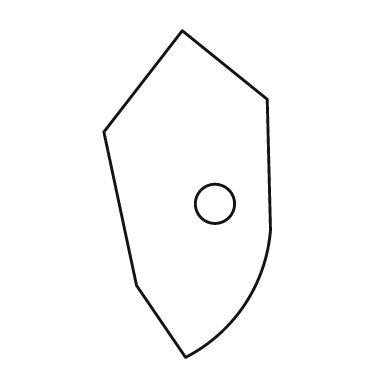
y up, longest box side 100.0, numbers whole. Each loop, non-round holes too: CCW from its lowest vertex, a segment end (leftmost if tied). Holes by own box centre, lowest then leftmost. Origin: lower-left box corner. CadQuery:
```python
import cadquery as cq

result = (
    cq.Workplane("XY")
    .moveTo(25.0, 0.0)
    .threePointArc((43.0, 16.0), (51.0, 39.0))
    .lineTo(50.0, 79.0)
    .lineTo(24.0, 100.0)
    .lineTo(0.0, 69.0)
    .lineTo(10.0, 22.0)
    .close()
    .moveTo(34.0, 47.0)
    .circle(6.0)
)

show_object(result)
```